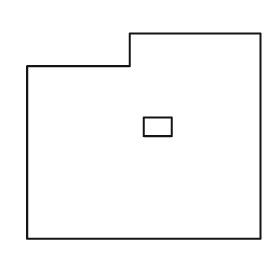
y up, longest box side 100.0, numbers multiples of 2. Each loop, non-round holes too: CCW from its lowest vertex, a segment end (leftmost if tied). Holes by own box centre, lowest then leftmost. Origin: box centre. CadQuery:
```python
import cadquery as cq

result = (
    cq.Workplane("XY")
    .moveTo(-50.0, -44.0)
    .lineTo(50.0, -44.0)
    .lineTo(50.0, 44.0)
    .lineTo(-6.0, 44.0)
    .lineTo(-6.0, 30.0)
    .lineTo(-50.0, 30.0)
    .close()
    .moveTo(0.0, 0.0)
    .lineTo(12.0, 0.0)
    .lineTo(12.0, 8.0)
    .lineTo(0.0, 8.0)
    .close()
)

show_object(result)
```